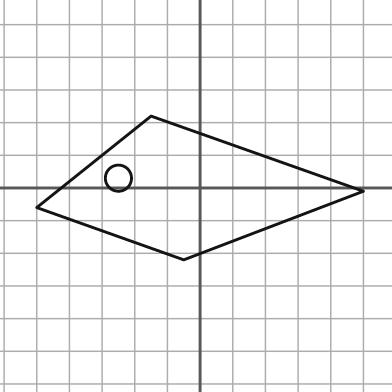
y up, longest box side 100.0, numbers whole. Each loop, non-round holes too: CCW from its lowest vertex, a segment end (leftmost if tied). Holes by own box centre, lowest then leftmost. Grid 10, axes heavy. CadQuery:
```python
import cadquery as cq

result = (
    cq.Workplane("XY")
    .moveTo(-5.0, -22.0)
    .lineTo(50.0, -1.0)
    .lineTo(-15.0, 22.0)
    .lineTo(-50.0, -6.0)
    .close()
    .moveTo(-25.0, 3.0)
    .circle(4.0)
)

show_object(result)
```